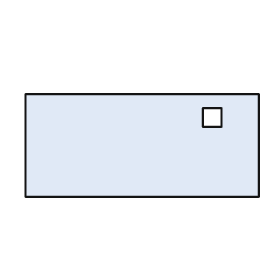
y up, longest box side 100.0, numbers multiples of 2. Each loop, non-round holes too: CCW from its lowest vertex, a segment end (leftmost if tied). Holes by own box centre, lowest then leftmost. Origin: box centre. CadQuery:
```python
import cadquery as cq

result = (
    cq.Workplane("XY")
    .moveTo(-50.0, -22.0)
    .lineTo(50.0, -22.0)
    .lineTo(50.0, 22.0)
    .lineTo(-50.0, 22.0)
    .close()
    .moveTo(26.0, 8.0)
    .lineTo(34.0, 8.0)
    .lineTo(34.0, 16.0)
    .lineTo(26.0, 16.0)
    .close()
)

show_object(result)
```